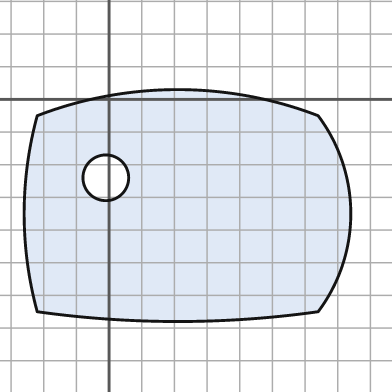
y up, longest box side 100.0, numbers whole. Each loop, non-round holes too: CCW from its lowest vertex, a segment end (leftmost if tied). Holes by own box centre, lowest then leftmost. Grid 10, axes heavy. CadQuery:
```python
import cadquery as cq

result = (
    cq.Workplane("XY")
    .moveTo(-22.0, -65.0)
    .threePointArc((21.0, -68.0), (64.0, -65.0))
    .threePointArc((74.0, -35.0), (64.0, -5.0))
    .threePointArc((21.0, 3.0), (-22.0, -5.0))
    .threePointArc((-26.0, -35.0), (-22.0, -65.0))
    .close()
    .moveTo(-1.0, -24.0)
    .circle(7.0)
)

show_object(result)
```